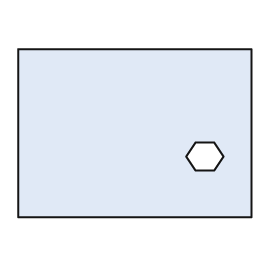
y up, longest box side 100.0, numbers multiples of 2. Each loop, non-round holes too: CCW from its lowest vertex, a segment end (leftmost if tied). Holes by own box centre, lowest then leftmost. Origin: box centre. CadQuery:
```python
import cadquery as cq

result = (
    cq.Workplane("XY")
    .moveTo(-50.0, -36.0)
    .lineTo(50.0, -36.0)
    .lineTo(50.0, 36.0)
    .lineTo(-50.0, 36.0)
    .close()
    .moveTo(26.0, -16.0)
    .lineTo(34.0, -16.0)
    .lineTo(38.0, -10.0)
    .lineTo(34.0, -4.0)
    .lineTo(26.0, -4.0)
    .lineTo(22.0, -10.0)
    .close()
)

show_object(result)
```